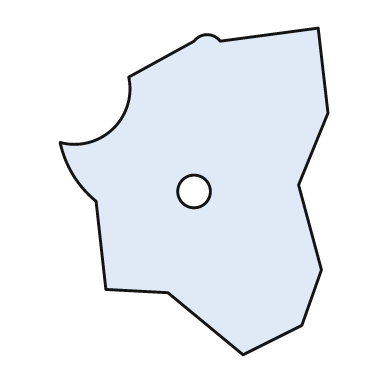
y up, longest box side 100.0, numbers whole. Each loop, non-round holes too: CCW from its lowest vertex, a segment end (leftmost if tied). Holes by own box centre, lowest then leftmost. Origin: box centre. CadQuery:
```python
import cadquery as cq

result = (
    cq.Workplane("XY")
    .moveTo(15.0, -50.0)
    .lineTo(33.0, -41.0)
    .lineTo(39.0, -24.0)
    .lineTo(32.0, 2.0)
    .lineTo(41.0, 24.0)
    .lineTo(38.0, 50.0)
    .lineTo(8.0, 46.0)
    .threePointArc((4.0, 48.0), (0.0, 46.0))
    .lineTo(-20.0, 35.0)
    .threePointArc((-25.0, 19.0), (-41.0, 15.0))
    .threePointArc((-37.0, 5.0), (-30.0, -3.0))
    .lineTo(-27.0, -30.0)
    .lineTo(-8.0, -31.0)
    .close()
    .moveTo(0.0, 0.0)
    .circle(5.0)
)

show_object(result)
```